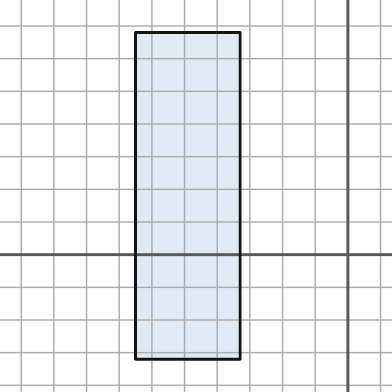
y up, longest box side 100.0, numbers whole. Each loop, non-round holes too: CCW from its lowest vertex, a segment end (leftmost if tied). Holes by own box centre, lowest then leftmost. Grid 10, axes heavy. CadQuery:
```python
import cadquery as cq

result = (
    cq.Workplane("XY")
    .moveTo(-65.0, -32.0)
    .lineTo(-33.0, -32.0)
    .lineTo(-33.0, 68.0)
    .lineTo(-65.0, 68.0)
    .close()
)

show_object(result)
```